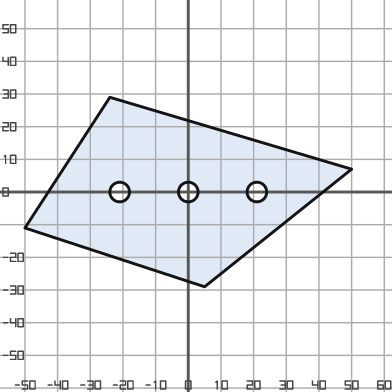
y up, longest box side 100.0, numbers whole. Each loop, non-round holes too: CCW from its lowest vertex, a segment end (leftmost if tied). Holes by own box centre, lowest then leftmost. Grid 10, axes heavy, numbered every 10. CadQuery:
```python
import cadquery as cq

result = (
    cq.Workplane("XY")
    .moveTo(5.0, -29.0)
    .lineTo(50.0, 7.0)
    .lineTo(-24.0, 29.0)
    .lineTo(-50.0, -11.0)
    .close()
    .moveTo(-21.0, 0.0)
    .circle(3.0)
    .moveTo(0.0, 0.0)
    .circle(3.0)
    .moveTo(21.0, 0.0)
    .circle(3.0)
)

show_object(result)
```